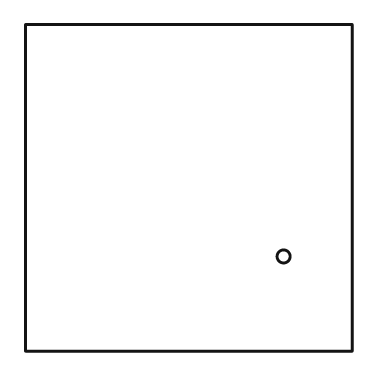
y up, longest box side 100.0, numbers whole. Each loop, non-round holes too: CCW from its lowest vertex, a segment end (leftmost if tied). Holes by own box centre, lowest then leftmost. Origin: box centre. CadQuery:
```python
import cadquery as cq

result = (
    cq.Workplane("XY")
    .moveTo(-50.0, -50.0)
    .lineTo(50.0, -50.0)
    .lineTo(50.0, 50.0)
    .lineTo(-50.0, 50.0)
    .close()
    .moveTo(29.0, -21.0)
    .circle(2.0)
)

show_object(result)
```